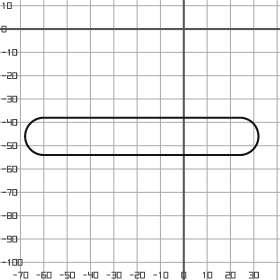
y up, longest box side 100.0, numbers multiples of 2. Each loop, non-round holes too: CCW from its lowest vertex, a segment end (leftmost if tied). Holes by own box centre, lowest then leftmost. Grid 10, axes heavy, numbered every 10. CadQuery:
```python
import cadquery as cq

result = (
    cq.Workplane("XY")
    .moveTo(-60.0, -54.0)
    .lineTo(24.0, -54.0)
    .threePointArc((32.0, -46.0), (24.0, -38.0))
    .lineTo(-60.0, -38.0)
    .threePointArc((-68.0, -46.0), (-60.0, -54.0))
    .close()
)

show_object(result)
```